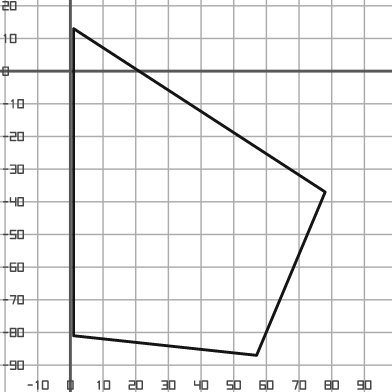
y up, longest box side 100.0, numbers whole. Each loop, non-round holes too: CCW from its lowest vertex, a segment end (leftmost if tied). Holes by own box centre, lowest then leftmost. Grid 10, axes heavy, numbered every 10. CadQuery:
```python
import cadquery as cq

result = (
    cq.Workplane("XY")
    .moveTo(57.0, -87.0)
    .lineTo(78.0, -37.0)
    .lineTo(1.0, 13.0)
    .lineTo(1.0, -81.0)
    .close()
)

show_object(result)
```